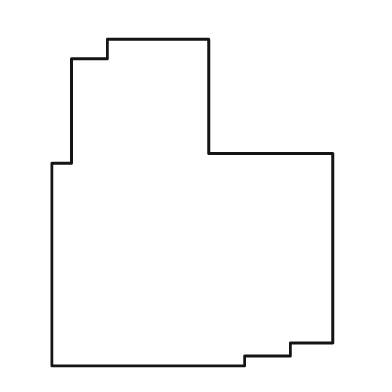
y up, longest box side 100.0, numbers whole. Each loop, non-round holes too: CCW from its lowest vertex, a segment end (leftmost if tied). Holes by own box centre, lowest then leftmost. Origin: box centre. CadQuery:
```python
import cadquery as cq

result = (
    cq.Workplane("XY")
    .moveTo(-43.0, -50.0)
    .lineTo(16.0, -50.0)
    .lineTo(16.0, -47.0)
    .lineTo(30.0, -47.0)
    .lineTo(30.0, -43.0)
    .lineTo(43.0, -43.0)
    .lineTo(43.0, 15.0)
    .lineTo(5.0, 15.0)
    .lineTo(5.0, 50.0)
    .lineTo(-26.0, 50.0)
    .lineTo(-26.0, 44.0)
    .lineTo(-37.0, 44.0)
    .lineTo(-37.0, 12.0)
    .lineTo(-43.0, 12.0)
    .close()
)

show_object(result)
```